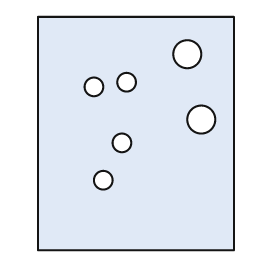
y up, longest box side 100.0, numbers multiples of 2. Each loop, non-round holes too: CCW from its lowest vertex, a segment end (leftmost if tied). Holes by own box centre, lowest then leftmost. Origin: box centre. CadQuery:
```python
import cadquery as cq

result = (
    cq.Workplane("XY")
    .moveTo(-42.0, -50.0)
    .lineTo(42.0, -50.0)
    .lineTo(42.0, 50.0)
    .lineTo(-42.0, 50.0)
    .close()
    .moveTo(-14.0, -20.0)
    .circle(4.0)
    .moveTo(-6.0, -4.0)
    .circle(4.0)
    .moveTo(28.0, 6.0)
    .circle(6.0)
    .moveTo(-18.0, 20.0)
    .circle(4.0)
    .moveTo(-4.0, 22.0)
    .circle(4.0)
    .moveTo(22.0, 34.0)
    .circle(6.0)
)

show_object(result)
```